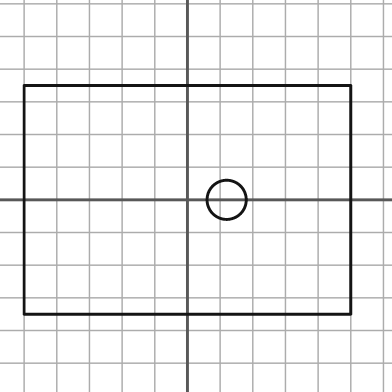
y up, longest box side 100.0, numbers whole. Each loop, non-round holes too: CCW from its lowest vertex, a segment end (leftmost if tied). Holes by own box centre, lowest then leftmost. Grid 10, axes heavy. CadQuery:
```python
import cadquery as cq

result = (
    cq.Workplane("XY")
    .moveTo(-50.0, -35.0)
    .lineTo(50.0, -35.0)
    .lineTo(50.0, 35.0)
    .lineTo(-50.0, 35.0)
    .close()
    .moveTo(12.0, 0.0)
    .circle(6.0)
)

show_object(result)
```